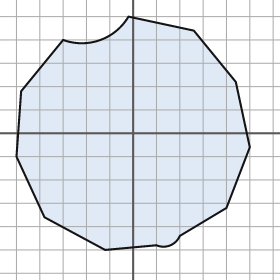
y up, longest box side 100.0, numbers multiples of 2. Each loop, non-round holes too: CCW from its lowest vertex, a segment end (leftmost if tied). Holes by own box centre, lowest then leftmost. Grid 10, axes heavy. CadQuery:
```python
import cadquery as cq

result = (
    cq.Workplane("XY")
    .moveTo(-12.0, -50.0)
    .lineTo(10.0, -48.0)
    .threePointArc((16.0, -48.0), (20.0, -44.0))
    .lineTo(40.0, -32.0)
    .lineTo(50.0, -6.0)
    .lineTo(44.0, 22.0)
    .lineTo(26.0, 44.0)
    .lineTo(-2.0, 50.0)
    .threePointArc((-14.0, 40.0), (-30.0, 40.0))
    .lineTo(-48.0, 18.0)
    .lineTo(-50.0, -10.0)
    .lineTo(-38.0, -36.0)
    .close()
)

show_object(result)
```